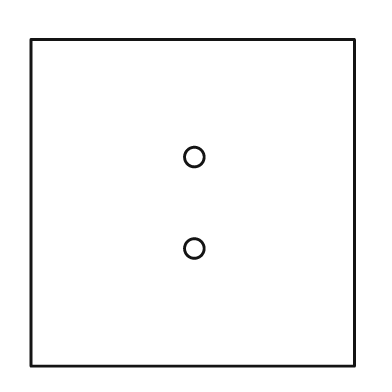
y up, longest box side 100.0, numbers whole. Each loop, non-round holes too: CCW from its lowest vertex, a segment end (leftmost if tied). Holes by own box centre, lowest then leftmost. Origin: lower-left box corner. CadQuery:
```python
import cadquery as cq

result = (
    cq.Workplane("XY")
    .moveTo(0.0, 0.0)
    .lineTo(99.0, 0.0)
    .lineTo(99.0, 100.0)
    .lineTo(0.0, 100.0)
    .close()
    .moveTo(50.0, 36.0)
    .circle(3.0)
    .moveTo(50.0, 64.0)
    .circle(3.0)
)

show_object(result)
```